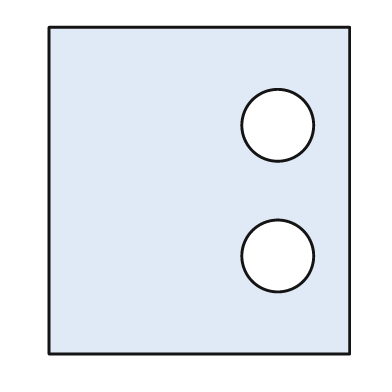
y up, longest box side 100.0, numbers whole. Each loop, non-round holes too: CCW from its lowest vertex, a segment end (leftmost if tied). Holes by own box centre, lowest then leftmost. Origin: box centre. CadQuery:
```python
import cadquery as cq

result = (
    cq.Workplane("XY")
    .moveTo(-46.0, -50.0)
    .lineTo(46.0, -50.0)
    .lineTo(46.0, 50.0)
    .lineTo(-46.0, 50.0)
    .close()
    .moveTo(24.0, -20.0)
    .circle(11.0)
    .moveTo(24.0, 20.0)
    .circle(11.0)
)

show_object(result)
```